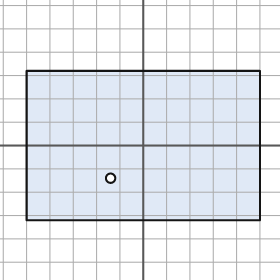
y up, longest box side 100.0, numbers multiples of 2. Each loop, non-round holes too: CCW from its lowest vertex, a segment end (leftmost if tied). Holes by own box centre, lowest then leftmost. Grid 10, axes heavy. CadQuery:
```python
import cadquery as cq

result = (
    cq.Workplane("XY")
    .moveTo(-50.0, -32.0)
    .lineTo(50.0, -32.0)
    .lineTo(50.0, 32.0)
    .lineTo(-50.0, 32.0)
    .close()
    .moveTo(-14.0, -14.0)
    .circle(2.0)
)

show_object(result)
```